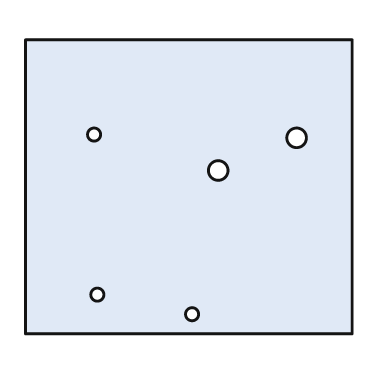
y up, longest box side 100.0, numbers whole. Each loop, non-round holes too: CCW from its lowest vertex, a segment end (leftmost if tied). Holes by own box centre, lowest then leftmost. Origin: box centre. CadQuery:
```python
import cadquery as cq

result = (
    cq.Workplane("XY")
    .moveTo(-50.0, -45.0)
    .lineTo(50.0, -45.0)
    .lineTo(50.0, 45.0)
    .lineTo(-50.0, 45.0)
    .close()
    .moveTo(1.0, -39.0)
    .circle(2.0)
    .moveTo(-28.0, -33.0)
    .circle(2.0)
    .moveTo(9.0, 5.0)
    .circle(3.0)
    .moveTo(33.0, 15.0)
    .circle(3.0)
    .moveTo(-29.0, 16.0)
    .circle(2.0)
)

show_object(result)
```